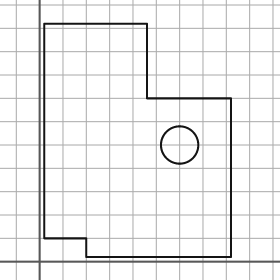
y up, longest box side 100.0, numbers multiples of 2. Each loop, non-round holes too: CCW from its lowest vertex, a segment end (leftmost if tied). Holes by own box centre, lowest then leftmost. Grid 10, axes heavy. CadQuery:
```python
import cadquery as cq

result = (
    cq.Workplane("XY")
    .moveTo(20.0, 2.0)
    .lineTo(82.0, 2.0)
    .lineTo(82.0, 70.0)
    .lineTo(46.0, 70.0)
    .lineTo(46.0, 102.0)
    .lineTo(2.0, 102.0)
    .lineTo(2.0, 10.0)
    .lineTo(20.0, 10.0)
    .close()
    .moveTo(60.0, 50.0)
    .circle(8.0)
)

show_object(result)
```